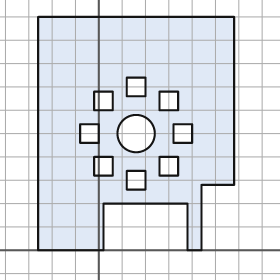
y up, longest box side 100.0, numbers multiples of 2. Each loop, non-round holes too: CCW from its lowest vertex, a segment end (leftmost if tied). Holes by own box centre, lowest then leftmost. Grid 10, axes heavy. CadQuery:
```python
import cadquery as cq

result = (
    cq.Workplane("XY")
    .moveTo(-26.0, 0.0)
    .lineTo(2.0, 0.0)
    .lineTo(2.0, 20.0)
    .lineTo(38.0, 20.0)
    .lineTo(38.0, 0.0)
    .lineTo(44.0, 0.0)
    .lineTo(44.0, 28.0)
    .lineTo(58.0, 28.0)
    .lineTo(58.0, 100.0)
    .lineTo(-26.0, 100.0)
    .close()
    .moveTo(12.0, 26.0)
    .lineTo(20.0, 26.0)
    .lineTo(20.0, 34.0)
    .lineTo(12.0, 34.0)
    .close()
    .moveTo(-2.0, 32.0)
    .lineTo(6.0, 32.0)
    .lineTo(6.0, 40.0)
    .lineTo(-2.0, 40.0)
    .close()
    .moveTo(26.0, 32.0)
    .lineTo(34.0, 32.0)
    .lineTo(34.0, 40.0)
    .lineTo(26.0, 40.0)
    .close()
    .moveTo(-8.0, 46.0)
    .lineTo(0.0, 46.0)
    .lineTo(0.0, 54.0)
    .lineTo(-8.0, 54.0)
    .close()
    .moveTo(16.0, 50.0)
    .circle(8.0)
    .moveTo(32.0, 46.0)
    .lineTo(40.0, 46.0)
    .lineTo(40.0, 54.0)
    .lineTo(32.0, 54.0)
    .close()
    .moveTo(-2.0, 60.0)
    .lineTo(6.0, 60.0)
    .lineTo(6.0, 68.0)
    .lineTo(-2.0, 68.0)
    .close()
    .moveTo(26.0, 60.0)
    .lineTo(34.0, 60.0)
    .lineTo(34.0, 68.0)
    .lineTo(26.0, 68.0)
    .close()
    .moveTo(12.0, 66.0)
    .lineTo(20.0, 66.0)
    .lineTo(20.0, 74.0)
    .lineTo(12.0, 74.0)
    .close()
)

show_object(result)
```